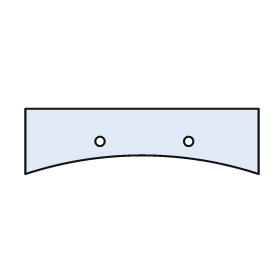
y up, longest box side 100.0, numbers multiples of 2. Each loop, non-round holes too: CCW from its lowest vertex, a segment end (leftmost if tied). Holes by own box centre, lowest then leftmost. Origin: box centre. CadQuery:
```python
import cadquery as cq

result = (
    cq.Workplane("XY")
    .moveTo(-50.0, -14.0)
    .threePointArc((0.0, -6.0), (50.0, -14.0))
    .lineTo(50.0, 14.0)
    .lineTo(-50.0, 14.0)
    .close()
    .moveTo(-18.0, 0.0)
    .circle(2.0)
    .moveTo(20.0, 0.0)
    .circle(2.0)
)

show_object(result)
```